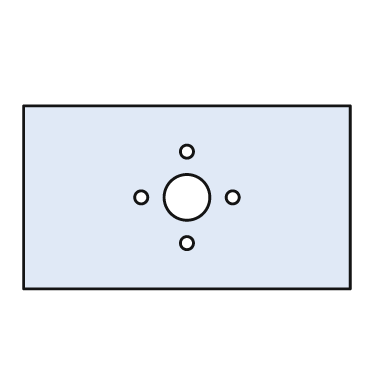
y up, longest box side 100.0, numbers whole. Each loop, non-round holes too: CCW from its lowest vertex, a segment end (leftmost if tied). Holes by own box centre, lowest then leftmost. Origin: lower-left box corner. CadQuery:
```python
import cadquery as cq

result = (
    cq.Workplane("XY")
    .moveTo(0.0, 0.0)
    .lineTo(100.0, 0.0)
    .lineTo(100.0, 56.0)
    .lineTo(0.0, 56.0)
    .close()
    .moveTo(50.0, 14.0)
    .circle(2.0)
    .moveTo(36.0, 28.0)
    .circle(2.0)
    .moveTo(50.0, 28.0)
    .circle(7.0)
    .moveTo(64.0, 28.0)
    .circle(2.0)
    .moveTo(50.0, 42.0)
    .circle(2.0)
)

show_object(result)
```